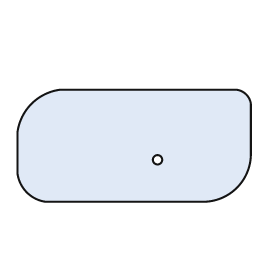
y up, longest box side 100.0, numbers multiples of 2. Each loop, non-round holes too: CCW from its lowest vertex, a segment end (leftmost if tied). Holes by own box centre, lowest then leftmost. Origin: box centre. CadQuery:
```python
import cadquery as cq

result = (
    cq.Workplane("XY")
    .moveTo(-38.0, -24.0)
    .lineTo(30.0, -24.0)
    .threePointArc((44.0, -18.0), (50.0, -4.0))
    .lineTo(50.0, 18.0)
    .threePointArc((48.0, 22.0), (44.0, 24.0))
    .lineTo(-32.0, 24.0)
    .threePointArc((-44.0, 18.0), (-50.0, 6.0))
    .lineTo(-50.0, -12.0)
    .threePointArc((-46.0, -20.0), (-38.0, -24.0))
    .close()
    .moveTo(10.0, -6.0)
    .circle(2.0)
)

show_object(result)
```